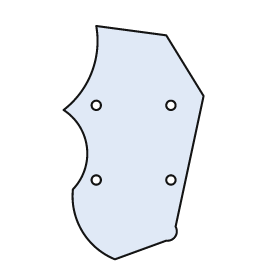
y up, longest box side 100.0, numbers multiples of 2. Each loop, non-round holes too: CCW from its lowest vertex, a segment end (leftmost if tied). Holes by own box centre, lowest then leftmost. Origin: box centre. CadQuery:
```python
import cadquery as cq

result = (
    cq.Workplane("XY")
    .moveTo(-8.0, -50.0)
    .lineTo(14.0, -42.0)
    .threePointArc((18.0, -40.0), (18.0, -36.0))
    .lineTo(30.0, 20.0)
    .lineTo(14.0, 46.0)
    .lineTo(-16.0, 50.0)
    .threePointArc((-18.0, 30.0), (-30.0, 14.0))
    .threePointArc((-20.0, -2.0), (-26.0, -20.0))
    .threePointArc((-22.0, -38.0), (-8.0, -50.0))
    .close()
    .moveTo(-16.0, -16.0)
    .circle(2.0)
    .moveTo(16.0, -16.0)
    .circle(2.0)
    .moveTo(-16.0, 16.0)
    .circle(2.0)
    .moveTo(16.0, 16.0)
    .circle(2.0)
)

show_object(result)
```